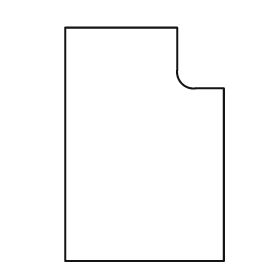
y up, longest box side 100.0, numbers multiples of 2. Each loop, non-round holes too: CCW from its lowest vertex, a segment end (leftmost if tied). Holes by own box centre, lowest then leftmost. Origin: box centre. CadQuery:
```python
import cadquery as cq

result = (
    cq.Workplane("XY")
    .moveTo(-34.0, -50.0)
    .lineTo(34.0, -50.0)
    .lineTo(34.0, 24.0)
    .lineTo(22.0, 24.0)
    .threePointArc((16.0, 26.0), (14.0, 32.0))
    .lineTo(14.0, 50.0)
    .lineTo(-34.0, 50.0)
    .close()
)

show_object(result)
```